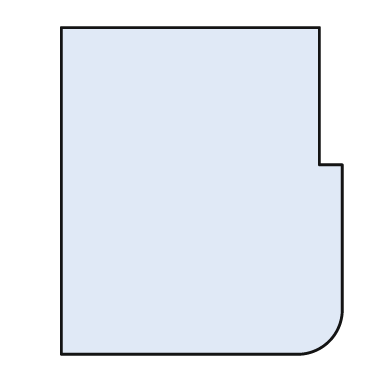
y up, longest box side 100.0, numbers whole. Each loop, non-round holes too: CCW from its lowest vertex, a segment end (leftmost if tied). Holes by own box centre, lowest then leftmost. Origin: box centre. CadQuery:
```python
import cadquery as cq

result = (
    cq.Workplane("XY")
    .moveTo(-43.0, -50.0)
    .lineTo(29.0, -50.0)
    .threePointArc((39.0, -46.0), (43.0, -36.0))
    .lineTo(43.0, 8.0)
    .lineTo(36.0, 8.0)
    .lineTo(36.0, 50.0)
    .lineTo(-43.0, 50.0)
    .close()
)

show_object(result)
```